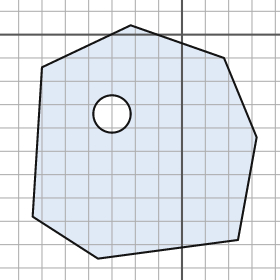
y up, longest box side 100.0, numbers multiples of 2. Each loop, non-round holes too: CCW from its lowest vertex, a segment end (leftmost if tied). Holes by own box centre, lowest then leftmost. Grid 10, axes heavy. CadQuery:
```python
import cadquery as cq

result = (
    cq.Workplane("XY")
    .moveTo(-36.0, -96.0)
    .lineTo(24.0, -88.0)
    .lineTo(32.0, -44.0)
    .lineTo(18.0, -10.0)
    .lineTo(-22.0, 4.0)
    .lineTo(-60.0, -14.0)
    .lineTo(-64.0, -78.0)
    .close()
    .moveTo(-30.0, -34.0)
    .circle(8.0)
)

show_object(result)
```